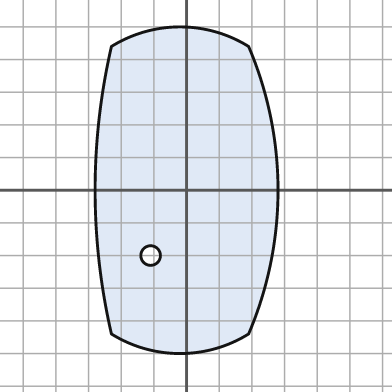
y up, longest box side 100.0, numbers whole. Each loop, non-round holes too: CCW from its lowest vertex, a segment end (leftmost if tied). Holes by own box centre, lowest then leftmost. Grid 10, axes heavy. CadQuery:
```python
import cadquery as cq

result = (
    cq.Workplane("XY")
    .moveTo(-23.0, -44.0)
    .threePointArc((-2.0, -50.0), (19.0, -44.0))
    .threePointArc((28.0, 0.0), (19.0, 44.0))
    .threePointArc((-2.0, 50.0), (-23.0, 44.0))
    .threePointArc((-28.0, 0.0), (-23.0, -44.0))
    .close()
    .moveTo(-11.0, -20.0)
    .circle(3.0)
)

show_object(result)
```